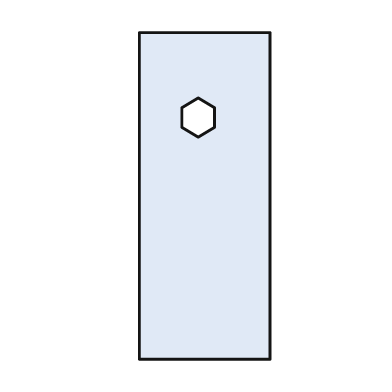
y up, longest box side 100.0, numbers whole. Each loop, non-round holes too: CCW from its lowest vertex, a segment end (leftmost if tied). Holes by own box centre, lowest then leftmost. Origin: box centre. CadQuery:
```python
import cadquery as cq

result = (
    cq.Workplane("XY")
    .moveTo(-20.0, -50.0)
    .lineTo(20.0, -50.0)
    .lineTo(20.0, 50.0)
    .lineTo(-20.0, 50.0)
    .close()
    .moveTo(-2.0, 18.0)
    .lineTo(3.0, 21.0)
    .lineTo(3.0, 27.0)
    .lineTo(-2.0, 30.0)
    .lineTo(-7.0, 27.0)
    .lineTo(-7.0, 21.0)
    .close()
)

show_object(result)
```